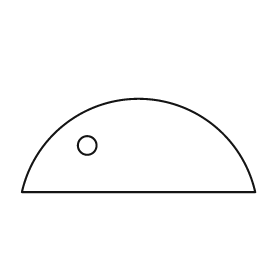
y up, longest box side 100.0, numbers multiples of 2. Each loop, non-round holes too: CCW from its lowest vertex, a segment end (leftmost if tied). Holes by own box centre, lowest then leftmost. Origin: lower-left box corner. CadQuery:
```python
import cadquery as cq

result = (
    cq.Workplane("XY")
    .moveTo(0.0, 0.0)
    .lineTo(100.0, 0.0)
    .threePointArc((50.0, 40.0), (0.0, 0.0))
    .close()
    .moveTo(28.0, 20.0)
    .circle(4.0)
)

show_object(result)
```